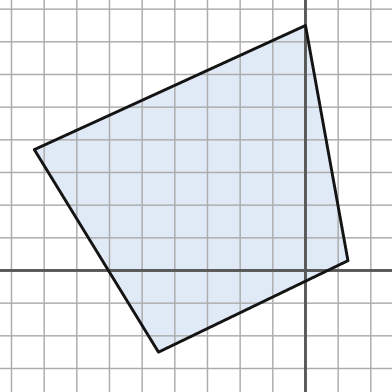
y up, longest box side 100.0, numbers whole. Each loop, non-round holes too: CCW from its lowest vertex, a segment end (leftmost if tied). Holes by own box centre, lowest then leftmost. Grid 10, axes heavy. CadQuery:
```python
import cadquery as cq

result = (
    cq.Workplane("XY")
    .moveTo(-45.0, -25.0)
    .lineTo(13.0, 3.0)
    .lineTo(0.0, 75.0)
    .lineTo(-83.0, 37.0)
    .close()
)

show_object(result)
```